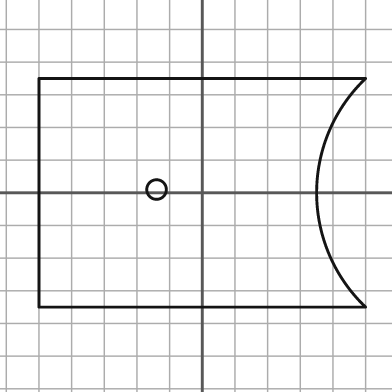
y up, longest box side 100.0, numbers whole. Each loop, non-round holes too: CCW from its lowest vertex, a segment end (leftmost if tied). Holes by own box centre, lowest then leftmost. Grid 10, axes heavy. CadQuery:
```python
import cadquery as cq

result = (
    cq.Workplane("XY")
    .moveTo(-50.0, -35.0)
    .lineTo(50.0, -35.0)
    .threePointArc((35.0, 0.0), (50.0, 35.0))
    .lineTo(-50.0, 35.0)
    .close()
    .moveTo(-14.0, 1.0)
    .circle(3.0)
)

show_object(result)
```